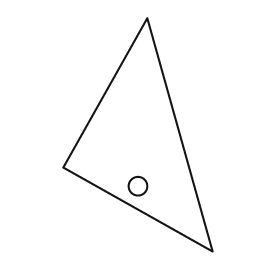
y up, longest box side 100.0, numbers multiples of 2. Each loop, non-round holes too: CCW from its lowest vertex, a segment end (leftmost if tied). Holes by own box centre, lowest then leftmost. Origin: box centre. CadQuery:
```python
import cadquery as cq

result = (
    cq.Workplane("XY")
    .moveTo(32.0, -50.0)
    .lineTo(4.0, 50.0)
    .lineTo(-32.0, -14.0)
    .close()
    .moveTo(0.0, -22.0)
    .circle(4.0)
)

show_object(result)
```